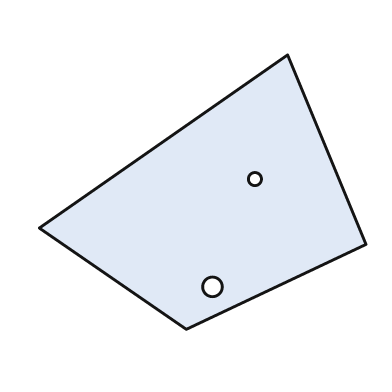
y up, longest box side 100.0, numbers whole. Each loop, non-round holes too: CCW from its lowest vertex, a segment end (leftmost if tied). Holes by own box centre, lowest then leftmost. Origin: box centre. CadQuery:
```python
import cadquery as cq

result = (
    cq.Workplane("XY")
    .moveTo(-5.0, -42.0)
    .lineTo(50.0, -16.0)
    .lineTo(26.0, 42.0)
    .lineTo(-50.0, -11.0)
    .close()
    .moveTo(3.0, -29.0)
    .circle(3.0)
    .moveTo(16.0, 4.0)
    .circle(2.0)
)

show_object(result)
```